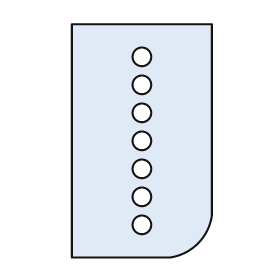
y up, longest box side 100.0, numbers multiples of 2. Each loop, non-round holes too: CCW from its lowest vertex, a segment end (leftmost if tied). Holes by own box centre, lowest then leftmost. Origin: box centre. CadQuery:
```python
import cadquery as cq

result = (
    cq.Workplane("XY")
    .moveTo(-30.0, -50.0)
    .lineTo(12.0, -50.0)
    .threePointArc((24.0, -44.0), (30.0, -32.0))
    .lineTo(30.0, 50.0)
    .lineTo(-30.0, 50.0)
    .close()
    .moveTo(0.0, -36.0)
    .circle(4.0)
    .moveTo(0.0, -24.0)
    .circle(4.0)
    .moveTo(0.0, -12.0)
    .circle(4.0)
    .moveTo(0.0, 0.0)
    .circle(4.0)
    .moveTo(0.0, 12.0)
    .circle(4.0)
    .moveTo(0.0, 24.0)
    .circle(4.0)
    .moveTo(0.0, 36.0)
    .circle(4.0)
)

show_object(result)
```